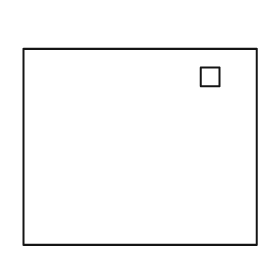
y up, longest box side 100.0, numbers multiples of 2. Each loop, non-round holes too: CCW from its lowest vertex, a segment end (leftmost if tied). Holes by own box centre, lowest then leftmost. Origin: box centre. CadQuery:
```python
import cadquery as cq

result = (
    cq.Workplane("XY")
    .moveTo(-50.0, -42.0)
    .lineTo(50.0, -42.0)
    .lineTo(50.0, 42.0)
    .lineTo(-50.0, 42.0)
    .close()
    .moveTo(26.0, 26.0)
    .lineTo(34.0, 26.0)
    .lineTo(34.0, 34.0)
    .lineTo(26.0, 34.0)
    .close()
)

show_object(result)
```